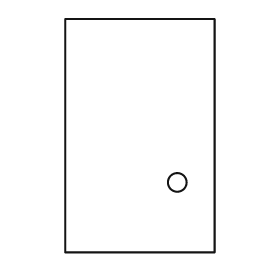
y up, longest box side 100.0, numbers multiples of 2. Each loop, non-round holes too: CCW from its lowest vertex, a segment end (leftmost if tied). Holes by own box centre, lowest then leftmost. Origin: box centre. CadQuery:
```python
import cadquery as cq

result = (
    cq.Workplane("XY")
    .moveTo(-32.0, -50.0)
    .lineTo(32.0, -50.0)
    .lineTo(32.0, 50.0)
    .lineTo(-32.0, 50.0)
    .close()
    .moveTo(16.0, -20.0)
    .circle(4.0)
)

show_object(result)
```